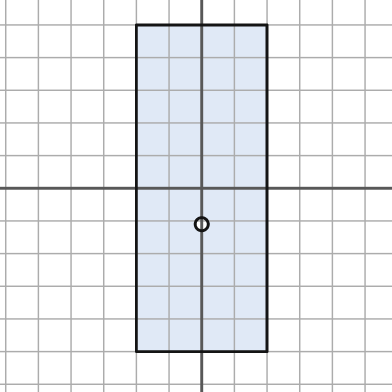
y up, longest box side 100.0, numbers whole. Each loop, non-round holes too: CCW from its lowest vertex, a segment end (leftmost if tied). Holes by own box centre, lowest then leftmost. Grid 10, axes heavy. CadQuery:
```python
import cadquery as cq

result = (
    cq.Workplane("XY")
    .moveTo(-20.0, -50.0)
    .lineTo(20.0, -50.0)
    .lineTo(20.0, 50.0)
    .lineTo(-20.0, 50.0)
    .close()
    .moveTo(0.0, -11.0)
    .circle(2.0)
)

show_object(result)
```